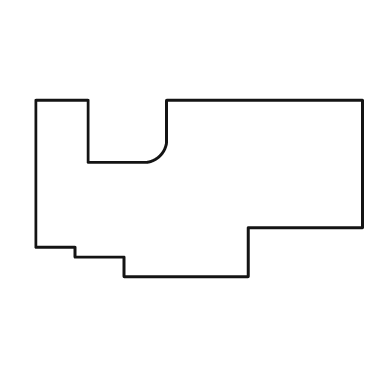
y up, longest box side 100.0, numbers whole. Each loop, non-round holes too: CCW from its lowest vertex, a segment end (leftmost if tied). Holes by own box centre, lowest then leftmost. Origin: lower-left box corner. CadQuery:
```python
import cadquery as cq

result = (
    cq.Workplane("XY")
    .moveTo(27.0, 0.0)
    .lineTo(65.0, 0.0)
    .lineTo(65.0, 15.0)
    .lineTo(100.0, 15.0)
    .lineTo(100.0, 54.0)
    .lineTo(40.0, 54.0)
    .lineTo(40.0, 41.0)
    .threePointArc((38.0, 37.0), (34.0, 35.0))
    .lineTo(16.0, 35.0)
    .lineTo(16.0, 54.0)
    .lineTo(0.0, 54.0)
    .lineTo(0.0, 9.0)
    .lineTo(12.0, 9.0)
    .lineTo(12.0, 6.0)
    .lineTo(27.0, 6.0)
    .close()
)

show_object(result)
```